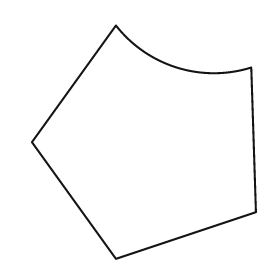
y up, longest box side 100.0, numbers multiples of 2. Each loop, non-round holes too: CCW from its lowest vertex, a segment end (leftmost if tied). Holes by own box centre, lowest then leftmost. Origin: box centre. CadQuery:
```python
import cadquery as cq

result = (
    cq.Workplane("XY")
    .moveTo(-12.0, -50.0)
    .lineTo(48.0, -30.0)
    .lineTo(46.0, 32.0)
    .threePointArc((14.0, 32.0), (-12.0, 50.0))
    .lineTo(-48.0, 0.0)
    .close()
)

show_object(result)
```